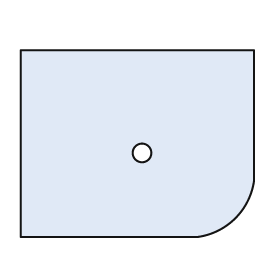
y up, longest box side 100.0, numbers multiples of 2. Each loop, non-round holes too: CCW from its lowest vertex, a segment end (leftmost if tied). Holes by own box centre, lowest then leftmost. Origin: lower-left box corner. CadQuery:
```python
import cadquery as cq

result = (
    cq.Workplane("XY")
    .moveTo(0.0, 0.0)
    .lineTo(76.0, 0.0)
    .threePointArc((92.0, 8.0), (100.0, 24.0))
    .lineTo(100.0, 80.0)
    .lineTo(0.0, 80.0)
    .close()
    .moveTo(52.0, 36.0)
    .circle(4.0)
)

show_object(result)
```